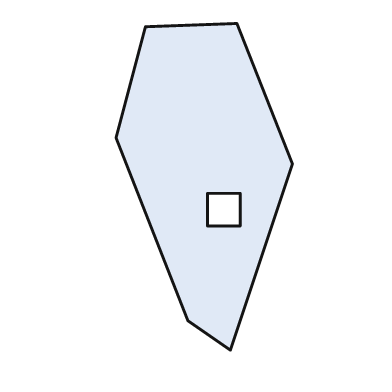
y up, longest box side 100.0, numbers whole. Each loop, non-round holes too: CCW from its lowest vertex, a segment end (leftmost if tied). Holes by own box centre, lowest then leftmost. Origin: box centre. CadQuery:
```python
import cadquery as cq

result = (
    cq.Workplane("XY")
    .moveTo(8.0, -50.0)
    .lineTo(27.0, 7.0)
    .lineTo(10.0, 50.0)
    .lineTo(-18.0, 49.0)
    .lineTo(-27.0, 15.0)
    .lineTo(-5.0, -41.0)
    .close()
    .moveTo(1.0, -12.0)
    .lineTo(11.0, -12.0)
    .lineTo(11.0, -2.0)
    .lineTo(1.0, -2.0)
    .close()
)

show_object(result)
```